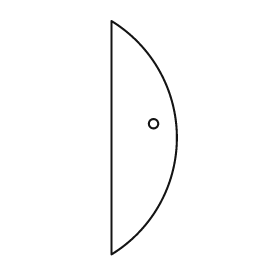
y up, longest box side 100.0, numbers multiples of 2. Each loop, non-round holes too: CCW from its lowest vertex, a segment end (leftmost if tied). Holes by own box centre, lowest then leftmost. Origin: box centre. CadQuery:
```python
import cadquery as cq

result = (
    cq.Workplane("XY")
    .moveTo(-14.0, -50.0)
    .threePointArc((14.0, 0.0), (-14.0, 50.0))
    .close()
    .moveTo(4.0, 6.0)
    .circle(2.0)
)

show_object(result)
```